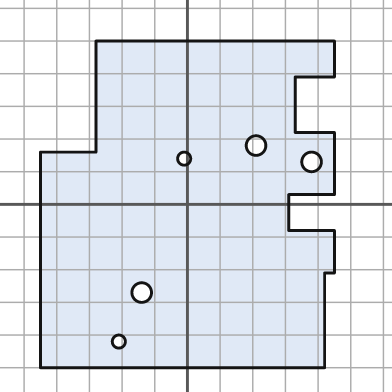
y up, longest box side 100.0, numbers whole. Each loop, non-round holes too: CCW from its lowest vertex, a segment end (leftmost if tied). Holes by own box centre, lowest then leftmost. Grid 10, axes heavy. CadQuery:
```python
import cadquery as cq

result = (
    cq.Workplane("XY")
    .moveTo(-45.0, -50.0)
    .lineTo(42.0, -50.0)
    .lineTo(42.0, -21.0)
    .lineTo(45.0, -21.0)
    .lineTo(45.0, -8.0)
    .lineTo(31.0, -8.0)
    .lineTo(31.0, 3.0)
    .lineTo(45.0, 3.0)
    .lineTo(45.0, 22.0)
    .lineTo(33.0, 22.0)
    .lineTo(33.0, 39.0)
    .lineTo(45.0, 39.0)
    .lineTo(45.0, 50.0)
    .lineTo(-28.0, 50.0)
    .lineTo(-28.0, 16.0)
    .lineTo(-45.0, 16.0)
    .close()
    .moveTo(-21.0, -42.0)
    .circle(2.0)
    .moveTo(-14.0, -27.0)
    .circle(3.0)
    .moveTo(38.0, 13.0)
    .circle(3.0)
    .moveTo(-1.0, 14.0)
    .circle(2.0)
    .moveTo(21.0, 18.0)
    .circle(3.0)
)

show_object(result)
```